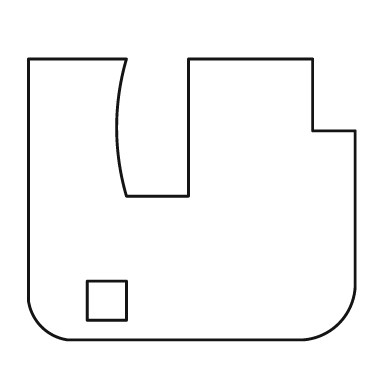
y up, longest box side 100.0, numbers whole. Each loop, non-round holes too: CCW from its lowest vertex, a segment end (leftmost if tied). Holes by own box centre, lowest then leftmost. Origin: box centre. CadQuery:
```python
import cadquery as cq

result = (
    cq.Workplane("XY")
    .moveTo(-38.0, -43.0)
    .lineTo(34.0, -43.0)
    .threePointArc((45.0, -38.0), (50.0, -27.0))
    .lineTo(50.0, 21.0)
    .lineTo(37.0, 21.0)
    .lineTo(37.0, 43.0)
    .lineTo(-1.0, 43.0)
    .lineTo(-1.0, 1.0)
    .lineTo(-20.0, 1.0)
    .threePointArc((-23.0, 22.0), (-20.0, 43.0))
    .lineTo(-50.0, 43.0)
    .lineTo(-50.0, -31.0)
    .threePointArc((-46.0, -39.0), (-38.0, -43.0))
    .close()
    .moveTo(-32.0, -37.0)
    .lineTo(-20.0, -37.0)
    .lineTo(-20.0, -25.0)
    .lineTo(-32.0, -25.0)
    .close()
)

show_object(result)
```